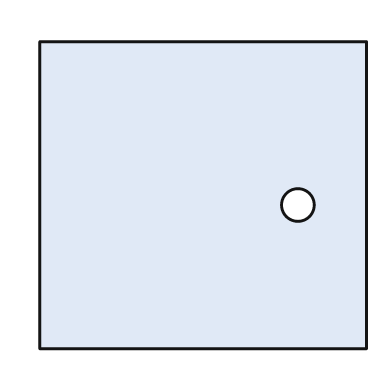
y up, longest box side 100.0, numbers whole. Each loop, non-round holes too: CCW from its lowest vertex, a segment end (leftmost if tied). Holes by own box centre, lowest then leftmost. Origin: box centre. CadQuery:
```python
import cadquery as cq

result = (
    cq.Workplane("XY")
    .moveTo(-50.0, -47.0)
    .lineTo(50.0, -47.0)
    .lineTo(50.0, 47.0)
    .lineTo(-50.0, 47.0)
    .close()
    .moveTo(29.0, -3.0)
    .circle(5.0)
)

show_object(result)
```